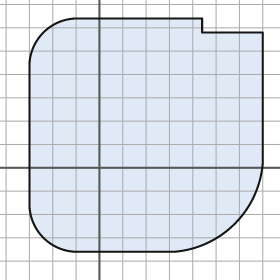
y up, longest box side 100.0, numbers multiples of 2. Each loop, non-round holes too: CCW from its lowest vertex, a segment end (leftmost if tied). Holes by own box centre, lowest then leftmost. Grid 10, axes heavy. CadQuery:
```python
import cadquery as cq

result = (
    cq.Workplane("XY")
    .moveTo(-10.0, -36.0)
    .lineTo(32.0, -36.0)
    .threePointArc((58.0, -24.0), (70.0, 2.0))
    .lineTo(70.0, 58.0)
    .lineTo(44.0, 58.0)
    .lineTo(44.0, 64.0)
    .lineTo(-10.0, 64.0)
    .threePointArc((-24.0, 58.0), (-30.0, 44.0))
    .lineTo(-30.0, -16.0)
    .threePointArc((-24.0, -30.0), (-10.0, -36.0))
    .close()
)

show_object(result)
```